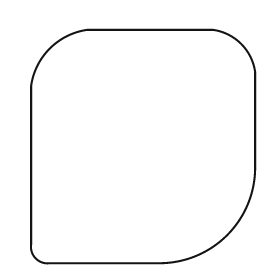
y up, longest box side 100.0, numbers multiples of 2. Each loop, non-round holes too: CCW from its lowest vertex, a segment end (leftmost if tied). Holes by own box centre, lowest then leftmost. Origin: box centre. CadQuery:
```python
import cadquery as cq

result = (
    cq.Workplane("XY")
    .moveTo(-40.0, -50.0)
    .lineTo(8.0, -50.0)
    .threePointArc((36.0, -38.0), (48.0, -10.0))
    .lineTo(48.0, 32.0)
    .threePointArc((42.0, 44.0), (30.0, 50.0))
    .lineTo(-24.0, 50.0)
    .threePointArc((-40.0, 42.0), (-48.0, 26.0))
    .lineTo(-48.0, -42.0)
    .threePointArc((-46.0, -48.0), (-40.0, -50.0))
    .close()
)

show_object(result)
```